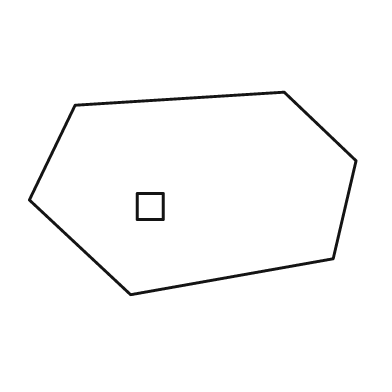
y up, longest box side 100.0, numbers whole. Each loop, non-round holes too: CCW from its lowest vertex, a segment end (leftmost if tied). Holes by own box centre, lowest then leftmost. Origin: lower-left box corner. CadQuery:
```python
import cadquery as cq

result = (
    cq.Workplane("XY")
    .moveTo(31.0, 0.0)
    .lineTo(93.0, 11.0)
    .lineTo(100.0, 41.0)
    .lineTo(78.0, 62.0)
    .lineTo(14.0, 58.0)
    .lineTo(0.0, 29.0)
    .close()
    .moveTo(33.0, 23.0)
    .lineTo(41.0, 23.0)
    .lineTo(41.0, 31.0)
    .lineTo(33.0, 31.0)
    .close()
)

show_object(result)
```